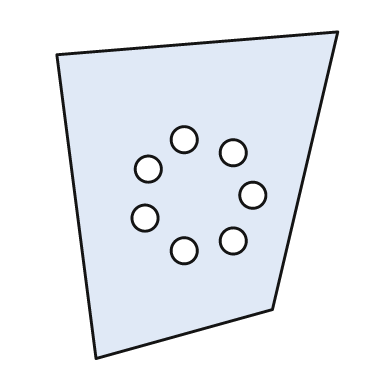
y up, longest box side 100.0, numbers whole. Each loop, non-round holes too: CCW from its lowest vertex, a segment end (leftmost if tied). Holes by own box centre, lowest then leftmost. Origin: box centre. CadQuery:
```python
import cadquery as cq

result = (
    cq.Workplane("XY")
    .moveTo(-31.0, -50.0)
    .lineTo(23.0, -35.0)
    .lineTo(43.0, 50.0)
    .lineTo(-43.0, 43.0)
    .close()
    .moveTo(-4.0, -17.0)
    .circle(4.0)
    .moveTo(11.0, -14.0)
    .circle(4.0)
    .moveTo(-16.0, -7.0)
    .circle(4.0)
    .moveTo(17.0, 0.0)
    .circle(4.0)
    .moveTo(-15.0, 8.0)
    .circle(4.0)
    .moveTo(11.0, 13.0)
    .circle(4.0)
    .moveTo(-4.0, 17.0)
    .circle(4.0)
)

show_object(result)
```